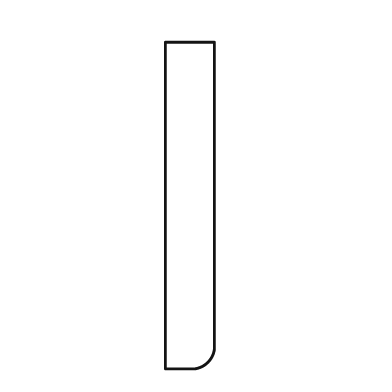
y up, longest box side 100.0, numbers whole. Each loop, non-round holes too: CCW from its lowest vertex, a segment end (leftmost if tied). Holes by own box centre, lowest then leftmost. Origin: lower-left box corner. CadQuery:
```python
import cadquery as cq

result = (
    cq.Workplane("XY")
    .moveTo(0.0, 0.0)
    .lineTo(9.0, 0.0)
    .threePointArc((13.0, 2.0), (15.0, 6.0))
    .lineTo(15.0, 100.0)
    .lineTo(0.0, 100.0)
    .close()
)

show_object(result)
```